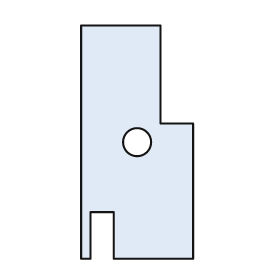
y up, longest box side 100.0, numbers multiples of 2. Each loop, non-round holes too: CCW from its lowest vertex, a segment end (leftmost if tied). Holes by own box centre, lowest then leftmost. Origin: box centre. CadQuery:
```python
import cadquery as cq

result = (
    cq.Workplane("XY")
    .moveTo(-24.0, -50.0)
    .lineTo(-20.0, -50.0)
    .lineTo(-20.0, -30.0)
    .lineTo(-10.0, -30.0)
    .lineTo(-10.0, -50.0)
    .lineTo(24.0, -50.0)
    .lineTo(24.0, 8.0)
    .lineTo(10.0, 8.0)
    .lineTo(10.0, 50.0)
    .lineTo(-24.0, 50.0)
    .close()
    .moveTo(0.0, 0.0)
    .circle(6.0)
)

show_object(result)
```